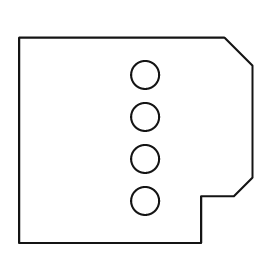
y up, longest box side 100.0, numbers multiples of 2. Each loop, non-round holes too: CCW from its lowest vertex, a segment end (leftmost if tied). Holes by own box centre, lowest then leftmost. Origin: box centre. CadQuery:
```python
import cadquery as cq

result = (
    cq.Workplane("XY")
    .moveTo(-50.0, -44.0)
    .lineTo(28.0, -44.0)
    .lineTo(28.0, -24.0)
    .lineTo(42.0, -24.0)
    .lineTo(50.0, -16.0)
    .lineTo(50.0, 32.0)
    .lineTo(38.0, 44.0)
    .lineTo(-50.0, 44.0)
    .close()
    .moveTo(4.0, -26.0)
    .circle(6.0)
    .moveTo(4.0, -8.0)
    .circle(6.0)
    .moveTo(4.0, 10.0)
    .circle(6.0)
    .moveTo(4.0, 28.0)
    .circle(6.0)
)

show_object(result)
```